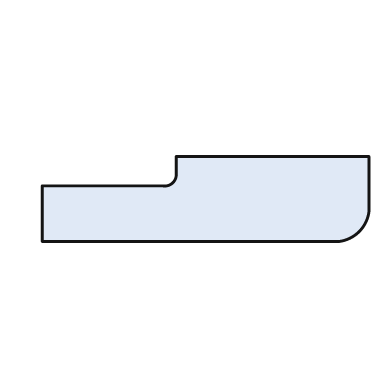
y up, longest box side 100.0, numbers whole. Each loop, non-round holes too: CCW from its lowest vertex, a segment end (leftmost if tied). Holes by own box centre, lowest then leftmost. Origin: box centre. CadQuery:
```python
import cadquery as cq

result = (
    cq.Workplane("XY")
    .moveTo(-50.0, -13.0)
    .lineTo(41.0, -13.0)
    .threePointArc((47.0, -10.0), (50.0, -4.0))
    .lineTo(50.0, 13.0)
    .lineTo(-9.0, 13.0)
    .lineTo(-9.0, 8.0)
    .threePointArc((-10.0, 5.0), (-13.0, 4.0))
    .lineTo(-50.0, 4.0)
    .close()
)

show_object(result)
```